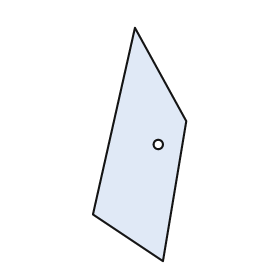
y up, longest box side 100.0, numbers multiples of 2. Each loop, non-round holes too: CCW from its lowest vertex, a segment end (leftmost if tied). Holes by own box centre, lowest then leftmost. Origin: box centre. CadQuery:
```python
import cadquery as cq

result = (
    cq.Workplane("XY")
    .moveTo(10.0, -50.0)
    .lineTo(20.0, 10.0)
    .lineTo(-2.0, 50.0)
    .lineTo(-20.0, -30.0)
    .close()
    .moveTo(8.0, 0.0)
    .circle(2.0)
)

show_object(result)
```